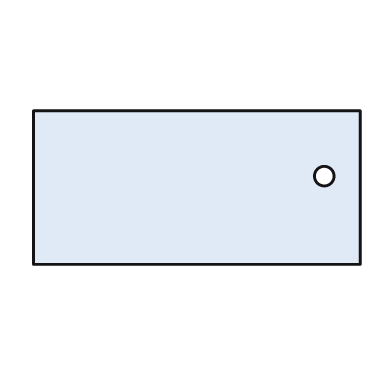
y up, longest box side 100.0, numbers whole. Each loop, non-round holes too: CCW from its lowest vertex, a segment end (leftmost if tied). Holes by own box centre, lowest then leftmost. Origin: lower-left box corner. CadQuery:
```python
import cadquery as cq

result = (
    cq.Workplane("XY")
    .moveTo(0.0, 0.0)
    .lineTo(100.0, 0.0)
    .lineTo(100.0, 47.0)
    .lineTo(0.0, 47.0)
    .close()
    .moveTo(89.0, 27.0)
    .circle(3.0)
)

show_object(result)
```